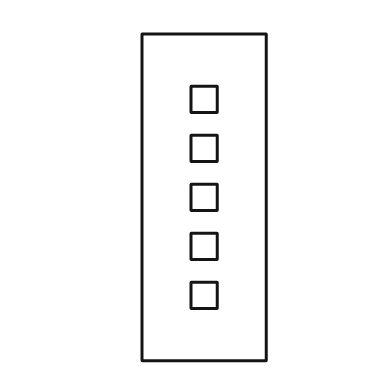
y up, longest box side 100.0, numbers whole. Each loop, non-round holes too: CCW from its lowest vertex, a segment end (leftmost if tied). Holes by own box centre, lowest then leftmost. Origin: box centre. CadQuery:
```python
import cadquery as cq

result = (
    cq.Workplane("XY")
    .moveTo(-19.0, -50.0)
    .lineTo(19.0, -50.0)
    .lineTo(19.0, 50.0)
    .lineTo(-19.0, 50.0)
    .close()
    .moveTo(-4.0, -34.0)
    .lineTo(4.0, -34.0)
    .lineTo(4.0, -26.0)
    .lineTo(-4.0, -26.0)
    .close()
    .moveTo(-4.0, -19.0)
    .lineTo(4.0, -19.0)
    .lineTo(4.0, -11.0)
    .lineTo(-4.0, -11.0)
    .close()
    .moveTo(-4.0, -4.0)
    .lineTo(4.0, -4.0)
    .lineTo(4.0, 4.0)
    .lineTo(-4.0, 4.0)
    .close()
    .moveTo(-4.0, 11.0)
    .lineTo(4.0, 11.0)
    .lineTo(4.0, 19.0)
    .lineTo(-4.0, 19.0)
    .close()
    .moveTo(-4.0, 26.0)
    .lineTo(4.0, 26.0)
    .lineTo(4.0, 34.0)
    .lineTo(-4.0, 34.0)
    .close()
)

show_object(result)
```